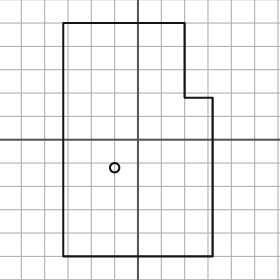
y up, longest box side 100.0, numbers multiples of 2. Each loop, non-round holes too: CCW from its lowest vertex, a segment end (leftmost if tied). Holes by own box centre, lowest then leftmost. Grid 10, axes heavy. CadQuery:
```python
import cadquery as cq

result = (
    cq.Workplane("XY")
    .moveTo(-32.0, -50.0)
    .lineTo(32.0, -50.0)
    .lineTo(32.0, 18.0)
    .lineTo(20.0, 18.0)
    .lineTo(20.0, 50.0)
    .lineTo(-32.0, 50.0)
    .close()
    .moveTo(-10.0, -12.0)
    .circle(2.0)
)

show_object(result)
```